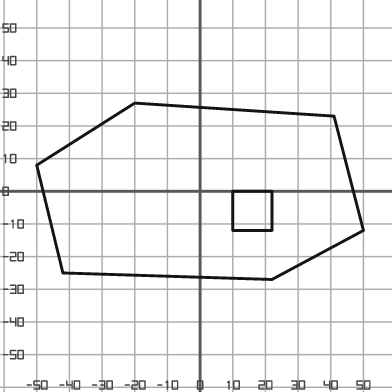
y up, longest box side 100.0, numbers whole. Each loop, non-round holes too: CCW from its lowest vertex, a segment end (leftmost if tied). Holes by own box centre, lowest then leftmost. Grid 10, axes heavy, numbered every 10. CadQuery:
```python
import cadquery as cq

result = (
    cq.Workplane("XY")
    .moveTo(22.0, -27.0)
    .lineTo(50.0, -12.0)
    .lineTo(41.0, 23.0)
    .lineTo(-20.0, 27.0)
    .lineTo(-50.0, 8.0)
    .lineTo(-42.0, -25.0)
    .close()
    .moveTo(10.0, -12.0)
    .lineTo(22.0, -12.0)
    .lineTo(22.0, 0.0)
    .lineTo(10.0, 0.0)
    .close()
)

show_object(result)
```